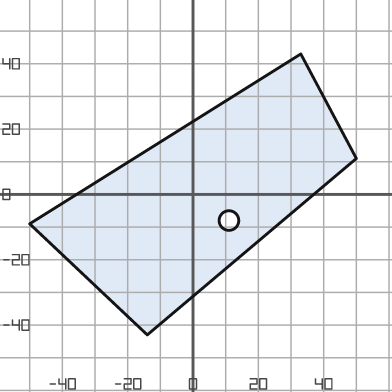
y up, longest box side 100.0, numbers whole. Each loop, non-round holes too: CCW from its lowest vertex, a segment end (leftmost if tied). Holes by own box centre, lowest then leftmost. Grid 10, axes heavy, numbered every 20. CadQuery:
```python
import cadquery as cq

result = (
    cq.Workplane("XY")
    .moveTo(-14.0, -43.0)
    .lineTo(50.0, 11.0)
    .lineTo(33.0, 43.0)
    .lineTo(-50.0, -9.0)
    .close()
    .moveTo(11.0, -8.0)
    .circle(3.0)
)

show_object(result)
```